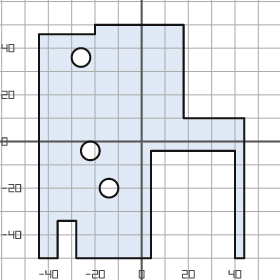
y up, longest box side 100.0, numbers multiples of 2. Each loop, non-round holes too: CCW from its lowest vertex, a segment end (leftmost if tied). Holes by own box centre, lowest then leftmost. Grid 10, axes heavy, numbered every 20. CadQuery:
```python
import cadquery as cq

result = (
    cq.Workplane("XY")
    .moveTo(-44.0, -50.0)
    .lineTo(-36.0, -50.0)
    .lineTo(-36.0, -34.0)
    .lineTo(-28.0, -34.0)
    .lineTo(-28.0, -50.0)
    .lineTo(4.0, -50.0)
    .lineTo(4.0, -4.0)
    .lineTo(40.0, -4.0)
    .lineTo(40.0, -50.0)
    .lineTo(44.0, -50.0)
    .lineTo(44.0, 10.0)
    .lineTo(18.0, 10.0)
    .lineTo(18.0, 50.0)
    .lineTo(-20.0, 50.0)
    .lineTo(-20.0, 46.0)
    .lineTo(-44.0, 46.0)
    .close()
    .moveTo(-14.0, -20.0)
    .circle(4.0)
    .moveTo(-22.0, -4.0)
    .circle(4.0)
    .moveTo(-26.0, 36.0)
    .circle(4.0)
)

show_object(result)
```